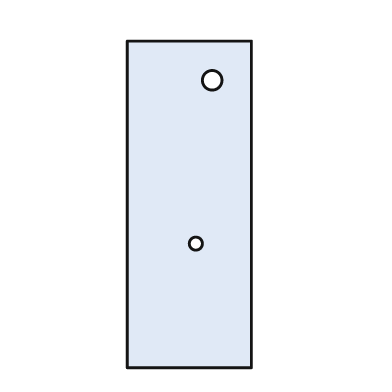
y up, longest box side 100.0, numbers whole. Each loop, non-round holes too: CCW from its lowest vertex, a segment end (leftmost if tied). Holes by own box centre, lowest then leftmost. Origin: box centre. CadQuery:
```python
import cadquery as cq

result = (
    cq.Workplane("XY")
    .moveTo(-19.0, -50.0)
    .lineTo(19.0, -50.0)
    .lineTo(19.0, 50.0)
    .lineTo(-19.0, 50.0)
    .close()
    .moveTo(2.0, -12.0)
    .circle(2.0)
    .moveTo(7.0, 38.0)
    .circle(3.0)
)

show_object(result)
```